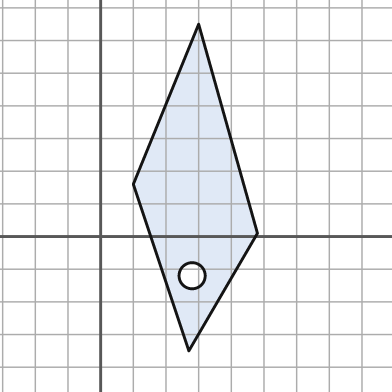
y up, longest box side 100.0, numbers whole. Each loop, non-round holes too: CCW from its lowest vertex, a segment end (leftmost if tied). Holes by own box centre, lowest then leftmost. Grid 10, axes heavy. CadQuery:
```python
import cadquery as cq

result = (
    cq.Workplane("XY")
    .moveTo(27.0, -35.0)
    .lineTo(48.0, 1.0)
    .lineTo(30.0, 65.0)
    .lineTo(10.0, 16.0)
    .close()
    .moveTo(28.0, -12.0)
    .circle(4.0)
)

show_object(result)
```